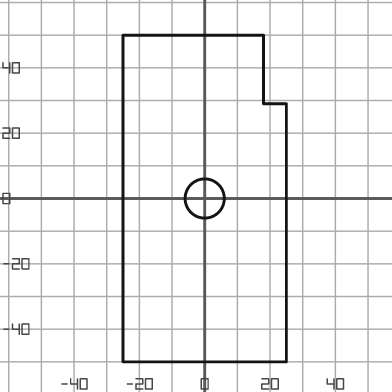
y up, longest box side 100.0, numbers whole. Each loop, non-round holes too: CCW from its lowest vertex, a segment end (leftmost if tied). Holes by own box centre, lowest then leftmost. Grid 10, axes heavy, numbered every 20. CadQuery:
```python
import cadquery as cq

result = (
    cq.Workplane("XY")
    .moveTo(-25.0, -50.0)
    .lineTo(25.0, -50.0)
    .lineTo(25.0, 29.0)
    .lineTo(18.0, 29.0)
    .lineTo(18.0, 50.0)
    .lineTo(-25.0, 50.0)
    .close()
    .moveTo(0.0, 0.0)
    .circle(6.0)
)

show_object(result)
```